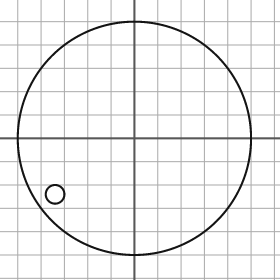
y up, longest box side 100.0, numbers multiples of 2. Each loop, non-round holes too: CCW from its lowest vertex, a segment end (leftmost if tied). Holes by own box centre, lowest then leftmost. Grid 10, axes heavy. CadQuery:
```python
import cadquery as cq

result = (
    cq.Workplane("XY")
    .moveTo(0.0, 0.0)
    .circle(50.0)
    .moveTo(-34.0, -24.0)
    .circle(4.0)
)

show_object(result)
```